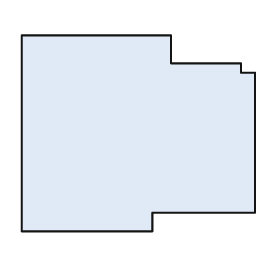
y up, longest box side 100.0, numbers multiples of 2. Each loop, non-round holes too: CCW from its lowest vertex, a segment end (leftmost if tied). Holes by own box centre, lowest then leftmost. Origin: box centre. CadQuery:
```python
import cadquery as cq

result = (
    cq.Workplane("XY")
    .moveTo(-50.0, -42.0)
    .lineTo(6.0, -42.0)
    .lineTo(6.0, -34.0)
    .lineTo(50.0, -34.0)
    .lineTo(50.0, 26.0)
    .lineTo(44.0, 26.0)
    .lineTo(44.0, 30.0)
    .lineTo(14.0, 30.0)
    .lineTo(14.0, 42.0)
    .lineTo(-50.0, 42.0)
    .close()
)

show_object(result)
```